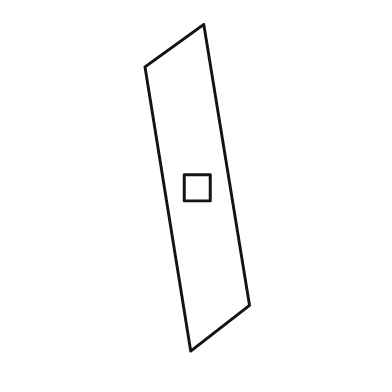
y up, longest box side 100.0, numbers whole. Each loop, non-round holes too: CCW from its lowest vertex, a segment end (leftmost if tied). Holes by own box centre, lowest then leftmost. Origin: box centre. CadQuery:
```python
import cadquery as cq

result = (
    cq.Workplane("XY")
    .moveTo(-2.0, -50.0)
    .lineTo(16.0, -36.0)
    .lineTo(2.0, 50.0)
    .lineTo(-16.0, 37.0)
    .close()
    .moveTo(-4.0, -4.0)
    .lineTo(4.0, -4.0)
    .lineTo(4.0, 4.0)
    .lineTo(-4.0, 4.0)
    .close()
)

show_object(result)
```